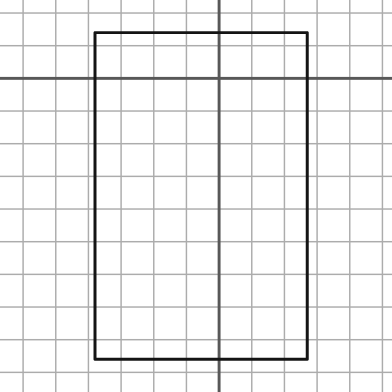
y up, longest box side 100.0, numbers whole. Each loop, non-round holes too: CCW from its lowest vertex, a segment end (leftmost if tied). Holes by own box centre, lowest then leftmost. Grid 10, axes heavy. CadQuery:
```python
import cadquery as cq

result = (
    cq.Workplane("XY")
    .moveTo(-38.0, -86.0)
    .lineTo(27.0, -86.0)
    .lineTo(27.0, 14.0)
    .lineTo(-38.0, 14.0)
    .close()
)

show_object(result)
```